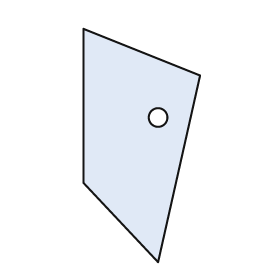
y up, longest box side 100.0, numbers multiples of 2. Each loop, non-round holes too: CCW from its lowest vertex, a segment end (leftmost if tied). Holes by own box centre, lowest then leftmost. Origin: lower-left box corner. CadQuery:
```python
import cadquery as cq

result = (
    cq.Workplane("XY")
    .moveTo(32.0, 0.0)
    .lineTo(50.0, 80.0)
    .lineTo(0.0, 100.0)
    .lineTo(0.0, 34.0)
    .close()
    .moveTo(32.0, 62.0)
    .circle(4.0)
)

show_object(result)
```